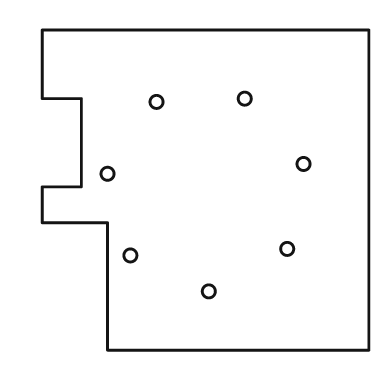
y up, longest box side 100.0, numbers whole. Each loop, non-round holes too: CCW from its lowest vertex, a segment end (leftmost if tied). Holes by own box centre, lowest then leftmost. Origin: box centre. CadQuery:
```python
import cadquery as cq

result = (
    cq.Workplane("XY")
    .moveTo(-30.0, -49.0)
    .lineTo(50.0, -49.0)
    .lineTo(50.0, 49.0)
    .lineTo(-50.0, 49.0)
    .lineTo(-50.0, 28.0)
    .lineTo(-38.0, 28.0)
    .lineTo(-38.0, 1.0)
    .lineTo(-50.0, 1.0)
    .lineTo(-50.0, -10.0)
    .lineTo(-30.0, -10.0)
    .close()
    .moveTo(1.0, -31.0)
    .circle(2.0)
    .moveTo(-23.0, -20.0)
    .circle(2.0)
    .moveTo(25.0, -18.0)
    .circle(2.0)
    .moveTo(-30.0, 5.0)
    .circle(2.0)
    .moveTo(30.0, 8.0)
    .circle(2.0)
    .moveTo(-15.0, 27.0)
    .circle(2.0)
    .moveTo(12.0, 28.0)
    .circle(2.0)
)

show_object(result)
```